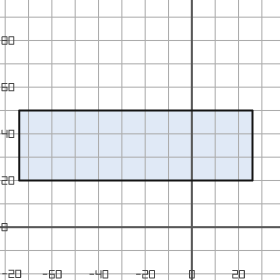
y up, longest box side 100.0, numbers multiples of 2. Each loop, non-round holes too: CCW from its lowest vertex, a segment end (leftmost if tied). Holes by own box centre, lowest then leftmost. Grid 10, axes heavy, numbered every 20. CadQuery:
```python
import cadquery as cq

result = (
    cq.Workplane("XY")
    .moveTo(-74.0, 20.0)
    .lineTo(26.0, 20.0)
    .lineTo(26.0, 50.0)
    .lineTo(-74.0, 50.0)
    .close()
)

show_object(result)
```